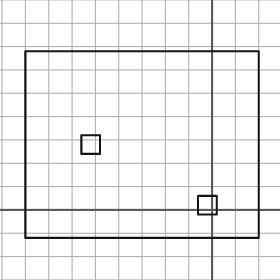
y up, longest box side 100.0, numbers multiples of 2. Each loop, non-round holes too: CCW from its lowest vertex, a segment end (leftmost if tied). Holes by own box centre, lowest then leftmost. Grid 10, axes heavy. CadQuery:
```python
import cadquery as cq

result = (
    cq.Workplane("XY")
    .moveTo(-80.0, -12.0)
    .lineTo(20.0, -12.0)
    .lineTo(20.0, 68.0)
    .lineTo(-80.0, 68.0)
    .close()
    .moveTo(-6.0, -2.0)
    .lineTo(2.0, -2.0)
    .lineTo(2.0, 6.0)
    .lineTo(-6.0, 6.0)
    .close()
    .moveTo(-56.0, 24.0)
    .lineTo(-48.0, 24.0)
    .lineTo(-48.0, 32.0)
    .lineTo(-56.0, 32.0)
    .close()
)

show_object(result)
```